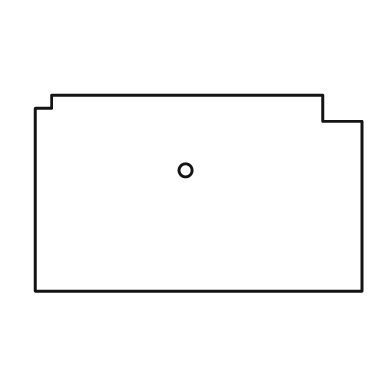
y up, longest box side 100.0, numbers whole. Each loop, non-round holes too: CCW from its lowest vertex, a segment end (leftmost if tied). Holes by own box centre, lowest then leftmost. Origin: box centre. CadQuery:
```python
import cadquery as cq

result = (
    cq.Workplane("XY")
    .moveTo(-50.0, -30.0)
    .lineTo(50.0, -30.0)
    .lineTo(50.0, 22.0)
    .lineTo(38.0, 22.0)
    .lineTo(38.0, 30.0)
    .lineTo(-45.0, 30.0)
    .lineTo(-45.0, 26.0)
    .lineTo(-50.0, 26.0)
    .close()
    .moveTo(-4.0, 7.0)
    .circle(2.0)
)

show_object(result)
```